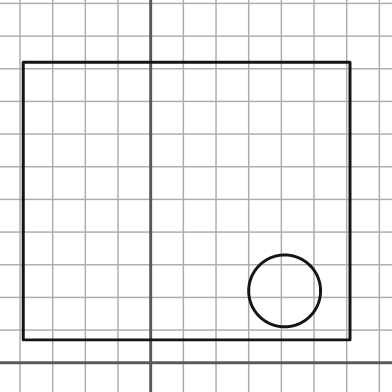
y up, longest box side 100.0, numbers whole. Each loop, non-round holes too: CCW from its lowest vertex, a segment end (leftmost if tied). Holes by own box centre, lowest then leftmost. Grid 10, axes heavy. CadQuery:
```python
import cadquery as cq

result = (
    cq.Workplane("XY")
    .moveTo(-39.0, 7.0)
    .lineTo(61.0, 7.0)
    .lineTo(61.0, 92.0)
    .lineTo(-39.0, 92.0)
    .close()
    .moveTo(41.0, 22.0)
    .circle(11.0)
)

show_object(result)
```